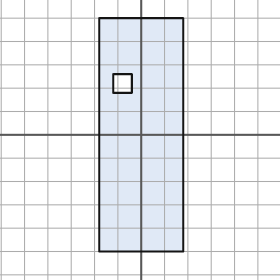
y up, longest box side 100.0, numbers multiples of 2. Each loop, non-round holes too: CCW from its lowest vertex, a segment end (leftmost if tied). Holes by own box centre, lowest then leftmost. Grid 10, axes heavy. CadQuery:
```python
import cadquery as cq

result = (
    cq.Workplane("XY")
    .moveTo(-18.0, -50.0)
    .lineTo(18.0, -50.0)
    .lineTo(18.0, 50.0)
    .lineTo(-18.0, 50.0)
    .close()
    .moveTo(-12.0, 18.0)
    .lineTo(-4.0, 18.0)
    .lineTo(-4.0, 26.0)
    .lineTo(-12.0, 26.0)
    .close()
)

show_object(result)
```